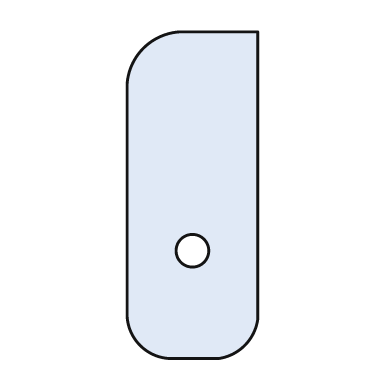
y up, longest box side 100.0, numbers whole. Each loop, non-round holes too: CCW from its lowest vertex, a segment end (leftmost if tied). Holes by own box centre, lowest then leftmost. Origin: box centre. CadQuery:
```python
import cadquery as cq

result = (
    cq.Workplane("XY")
    .moveTo(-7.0, -50.0)
    .lineTo(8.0, -50.0)
    .threePointArc((16.0, -46.0), (20.0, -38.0))
    .lineTo(20.0, 50.0)
    .lineTo(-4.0, 50.0)
    .threePointArc((-15.0, 45.0), (-20.0, 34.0))
    .lineTo(-20.0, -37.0)
    .threePointArc((-16.0, -46.0), (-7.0, -50.0))
    .close()
    .moveTo(0.0, -17.0)
    .circle(5.0)
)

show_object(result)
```